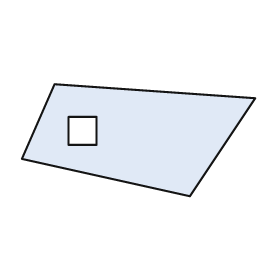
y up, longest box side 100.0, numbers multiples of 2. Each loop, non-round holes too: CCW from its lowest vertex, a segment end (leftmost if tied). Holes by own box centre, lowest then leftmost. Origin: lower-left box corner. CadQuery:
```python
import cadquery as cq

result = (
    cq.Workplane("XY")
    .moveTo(72.0, 0.0)
    .lineTo(100.0, 42.0)
    .lineTo(14.0, 48.0)
    .lineTo(0.0, 16.0)
    .close()
    .moveTo(20.0, 22.0)
    .lineTo(32.0, 22.0)
    .lineTo(32.0, 34.0)
    .lineTo(20.0, 34.0)
    .close()
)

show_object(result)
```